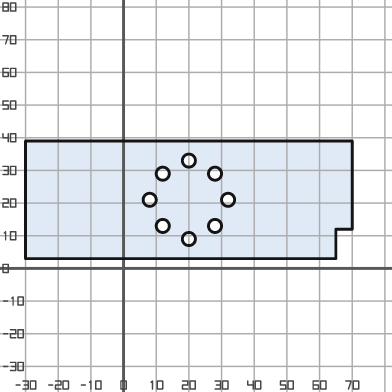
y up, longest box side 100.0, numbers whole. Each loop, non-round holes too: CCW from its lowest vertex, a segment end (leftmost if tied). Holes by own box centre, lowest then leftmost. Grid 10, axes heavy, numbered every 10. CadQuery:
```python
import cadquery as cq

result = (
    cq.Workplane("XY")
    .moveTo(-30.0, 3.0)
    .lineTo(65.0, 3.0)
    .lineTo(65.0, 12.0)
    .lineTo(70.0, 12.0)
    .lineTo(70.0, 39.0)
    .lineTo(-30.0, 39.0)
    .close()
    .moveTo(20.0, 9.0)
    .circle(2.0)
    .moveTo(12.0, 13.0)
    .circle(2.0)
    .moveTo(28.0, 13.0)
    .circle(2.0)
    .moveTo(8.0, 21.0)
    .circle(2.0)
    .moveTo(32.0, 21.0)
    .circle(2.0)
    .moveTo(12.0, 29.0)
    .circle(2.0)
    .moveTo(28.0, 29.0)
    .circle(2.0)
    .moveTo(20.0, 33.0)
    .circle(2.0)
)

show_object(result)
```